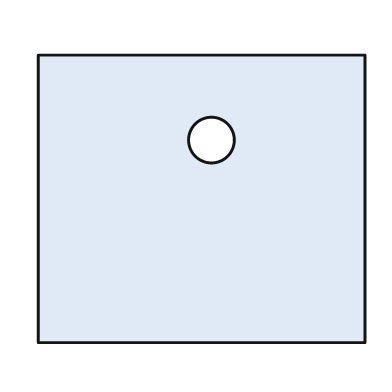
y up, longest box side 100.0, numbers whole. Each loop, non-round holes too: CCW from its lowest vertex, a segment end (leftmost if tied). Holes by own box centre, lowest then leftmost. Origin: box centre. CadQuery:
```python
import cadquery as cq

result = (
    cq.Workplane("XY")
    .moveTo(-50.0, -44.0)
    .lineTo(50.0, -44.0)
    .lineTo(50.0, 44.0)
    .lineTo(-50.0, 44.0)
    .close()
    .moveTo(3.0, 18.0)
    .circle(7.0)
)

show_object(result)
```